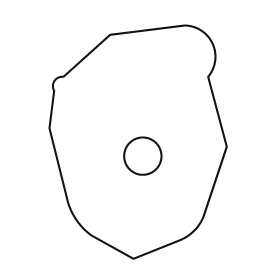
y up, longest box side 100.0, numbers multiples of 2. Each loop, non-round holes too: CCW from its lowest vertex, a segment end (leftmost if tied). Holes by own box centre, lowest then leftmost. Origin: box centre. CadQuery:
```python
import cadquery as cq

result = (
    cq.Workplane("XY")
    .moveTo(-2.0, -50.0)
    .lineTo(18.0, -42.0)
    .threePointArc((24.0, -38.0), (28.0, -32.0))
    .lineTo(38.0, -2.0)
    .lineTo(30.0, 28.0)
    .threePointArc((32.0, 42.0), (20.0, 50.0))
    .lineTo(-12.0, 46.0)
    .lineTo(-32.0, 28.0)
    .threePointArc((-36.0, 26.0), (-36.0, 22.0))
    .lineTo(-38.0, 6.0)
    .lineTo(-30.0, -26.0)
    .threePointArc((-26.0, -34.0), (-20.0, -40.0))
    .close()
    .moveTo(2.0, -6.0)
    .circle(8.0)
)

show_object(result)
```